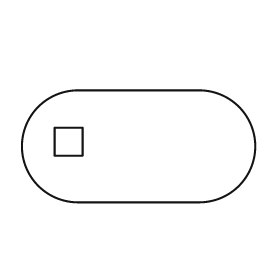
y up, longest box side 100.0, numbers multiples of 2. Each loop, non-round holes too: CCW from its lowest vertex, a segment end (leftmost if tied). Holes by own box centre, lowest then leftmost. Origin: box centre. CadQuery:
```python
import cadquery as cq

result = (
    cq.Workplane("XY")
    .moveTo(-26.0, -24.0)
    .lineTo(26.0, -24.0)
    .threePointArc((50.0, 0.0), (26.0, 24.0))
    .lineTo(-26.0, 24.0)
    .threePointArc((-50.0, 0.0), (-26.0, -24.0))
    .close()
    .moveTo(-36.0, -4.0)
    .lineTo(-24.0, -4.0)
    .lineTo(-24.0, 8.0)
    .lineTo(-36.0, 8.0)
    .close()
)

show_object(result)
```